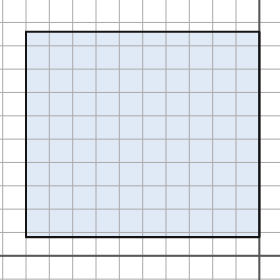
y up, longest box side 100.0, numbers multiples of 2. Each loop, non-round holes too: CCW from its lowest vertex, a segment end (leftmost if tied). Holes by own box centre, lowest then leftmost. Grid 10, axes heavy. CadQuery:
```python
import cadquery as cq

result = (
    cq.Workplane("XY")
    .moveTo(-100.0, 8.0)
    .lineTo(0.0, 8.0)
    .lineTo(0.0, 96.0)
    .lineTo(-100.0, 96.0)
    .close()
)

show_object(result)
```